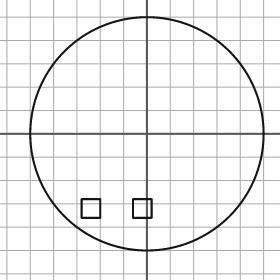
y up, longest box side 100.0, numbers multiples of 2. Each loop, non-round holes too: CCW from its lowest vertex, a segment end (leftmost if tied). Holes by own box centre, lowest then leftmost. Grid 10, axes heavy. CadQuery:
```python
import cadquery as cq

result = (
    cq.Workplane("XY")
    .moveTo(0.0, 0.0)
    .circle(50.0)
    .moveTo(-28.0, -36.0)
    .lineTo(-20.0, -36.0)
    .lineTo(-20.0, -28.0)
    .lineTo(-28.0, -28.0)
    .close()
    .moveTo(-6.0, -36.0)
    .lineTo(2.0, -36.0)
    .lineTo(2.0, -28.0)
    .lineTo(-6.0, -28.0)
    .close()
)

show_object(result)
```